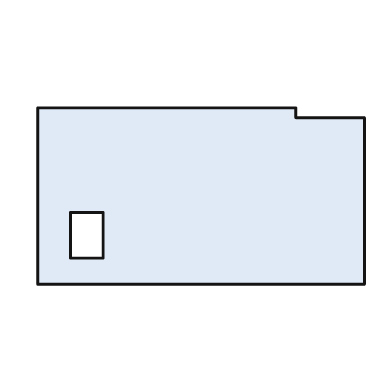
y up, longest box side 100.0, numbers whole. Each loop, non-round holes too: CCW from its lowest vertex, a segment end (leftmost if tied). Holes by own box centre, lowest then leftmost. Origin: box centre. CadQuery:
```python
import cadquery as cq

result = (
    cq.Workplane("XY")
    .moveTo(-50.0, -27.0)
    .lineTo(50.0, -27.0)
    .lineTo(50.0, 24.0)
    .lineTo(29.0, 24.0)
    .lineTo(29.0, 27.0)
    .lineTo(-50.0, 27.0)
    .close()
    .moveTo(-40.0, -19.0)
    .lineTo(-30.0, -19.0)
    .lineTo(-30.0, -5.0)
    .lineTo(-40.0, -5.0)
    .close()
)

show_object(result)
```